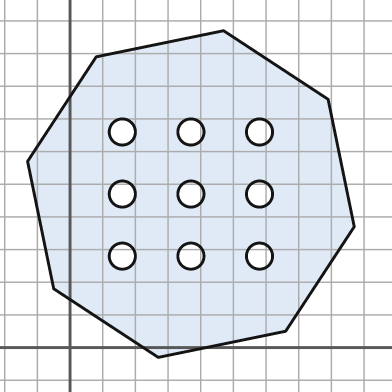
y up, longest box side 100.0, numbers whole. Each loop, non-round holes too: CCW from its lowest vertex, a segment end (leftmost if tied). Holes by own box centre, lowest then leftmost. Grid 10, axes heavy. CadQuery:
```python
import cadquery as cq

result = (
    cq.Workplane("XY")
    .moveTo(27.0, -3.0)
    .lineTo(66.0, 5.0)
    .lineTo(87.0, 37.0)
    .lineTo(79.0, 76.0)
    .lineTo(47.0, 97.0)
    .lineTo(8.0, 89.0)
    .lineTo(-13.0, 57.0)
    .lineTo(-5.0, 18.0)
    .close()
    .moveTo(16.0, 28.0)
    .circle(4.0)
    .moveTo(37.0, 28.0)
    .circle(4.0)
    .moveTo(58.0, 28.0)
    .circle(4.0)
    .moveTo(16.0, 47.0)
    .circle(4.0)
    .moveTo(37.0, 47.0)
    .circle(4.0)
    .moveTo(58.0, 47.0)
    .circle(4.0)
    .moveTo(16.0, 66.0)
    .circle(4.0)
    .moveTo(37.0, 66.0)
    .circle(4.0)
    .moveTo(58.0, 66.0)
    .circle(4.0)
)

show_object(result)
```